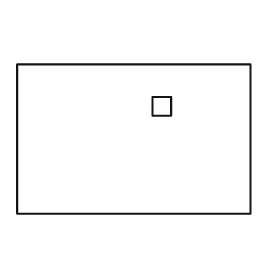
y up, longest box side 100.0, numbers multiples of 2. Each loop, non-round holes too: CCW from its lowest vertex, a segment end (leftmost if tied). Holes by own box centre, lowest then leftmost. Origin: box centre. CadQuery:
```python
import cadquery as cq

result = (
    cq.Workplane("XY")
    .moveTo(-50.0, -32.0)
    .lineTo(50.0, -32.0)
    .lineTo(50.0, 32.0)
    .lineTo(-50.0, 32.0)
    .close()
    .moveTo(8.0, 10.0)
    .lineTo(16.0, 10.0)
    .lineTo(16.0, 18.0)
    .lineTo(8.0, 18.0)
    .close()
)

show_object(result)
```